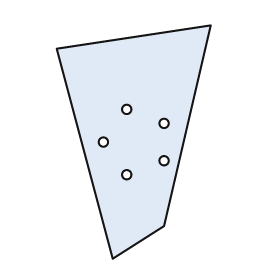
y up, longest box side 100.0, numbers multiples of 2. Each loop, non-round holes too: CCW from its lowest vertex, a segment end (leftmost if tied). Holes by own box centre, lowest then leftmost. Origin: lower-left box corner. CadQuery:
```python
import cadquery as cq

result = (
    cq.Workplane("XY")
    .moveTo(24.0, 0.0)
    .lineTo(46.0, 14.0)
    .lineTo(66.0, 100.0)
    .lineTo(0.0, 90.0)
    .close()
    .moveTo(30.0, 36.0)
    .circle(2.0)
    .moveTo(46.0, 42.0)
    .circle(2.0)
    .moveTo(20.0, 50.0)
    .circle(2.0)
    .moveTo(46.0, 58.0)
    .circle(2.0)
    .moveTo(30.0, 64.0)
    .circle(2.0)
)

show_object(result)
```